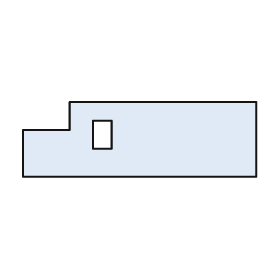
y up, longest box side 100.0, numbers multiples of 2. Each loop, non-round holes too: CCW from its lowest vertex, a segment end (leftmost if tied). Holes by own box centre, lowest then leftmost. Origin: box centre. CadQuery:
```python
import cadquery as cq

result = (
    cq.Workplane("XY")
    .moveTo(-50.0, -16.0)
    .lineTo(50.0, -16.0)
    .lineTo(50.0, 16.0)
    .lineTo(-30.0, 16.0)
    .lineTo(-30.0, 4.0)
    .lineTo(-50.0, 4.0)
    .close()
    .moveTo(-20.0, -4.0)
    .lineTo(-12.0, -4.0)
    .lineTo(-12.0, 8.0)
    .lineTo(-20.0, 8.0)
    .close()
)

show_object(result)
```